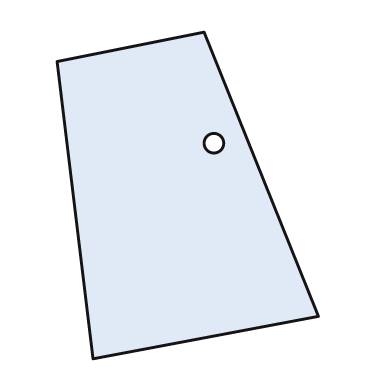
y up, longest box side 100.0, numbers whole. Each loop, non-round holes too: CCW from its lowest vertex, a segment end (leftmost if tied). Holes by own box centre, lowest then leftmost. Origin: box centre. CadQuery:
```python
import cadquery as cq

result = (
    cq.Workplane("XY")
    .moveTo(-29.0, -50.0)
    .lineTo(40.0, -37.0)
    .lineTo(5.0, 50.0)
    .lineTo(-40.0, 41.0)
    .close()
    .moveTo(8.0, 16.0)
    .circle(3.0)
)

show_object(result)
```